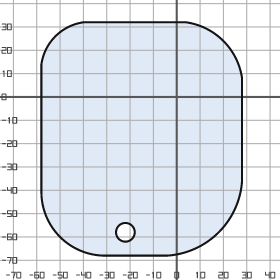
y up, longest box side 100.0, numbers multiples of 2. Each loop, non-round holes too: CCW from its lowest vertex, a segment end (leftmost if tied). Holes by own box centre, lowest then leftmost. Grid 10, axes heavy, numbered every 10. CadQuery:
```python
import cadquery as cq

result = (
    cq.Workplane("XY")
    .moveTo(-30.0, -68.0)
    .lineTo(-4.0, -68.0)
    .threePointArc((18.0, -58.0), (28.0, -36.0))
    .lineTo(28.0, 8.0)
    .threePointArc((20.0, 24.0), (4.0, 32.0))
    .lineTo(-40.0, 32.0)
    .threePointArc((-52.0, 26.0), (-58.0, 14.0))
    .lineTo(-58.0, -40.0)
    .threePointArc((-50.0, -60.0), (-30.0, -68.0))
    .close()
    .moveTo(-22.0, -58.0)
    .circle(4.0)
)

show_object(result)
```